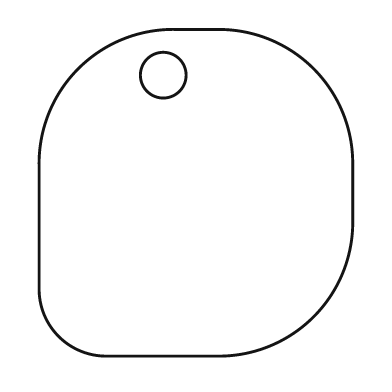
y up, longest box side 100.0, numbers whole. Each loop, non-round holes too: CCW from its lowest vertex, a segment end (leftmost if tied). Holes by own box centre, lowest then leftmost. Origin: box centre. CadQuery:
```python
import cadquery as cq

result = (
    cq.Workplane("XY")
    .moveTo(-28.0, -50.0)
    .lineTo(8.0, -50.0)
    .threePointArc((36.0, -38.0), (48.0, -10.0))
    .lineTo(48.0, 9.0)
    .threePointArc((36.0, 38.0), (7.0, 50.0))
    .lineTo(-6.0, 50.0)
    .threePointArc((-36.0, 38.0), (-48.0, 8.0))
    .lineTo(-48.0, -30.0)
    .threePointArc((-42.0, -44.0), (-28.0, -50.0))
    .close()
    .moveTo(-10.0, 36.0)
    .circle(7.0)
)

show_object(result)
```